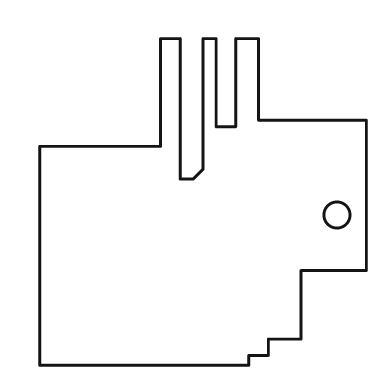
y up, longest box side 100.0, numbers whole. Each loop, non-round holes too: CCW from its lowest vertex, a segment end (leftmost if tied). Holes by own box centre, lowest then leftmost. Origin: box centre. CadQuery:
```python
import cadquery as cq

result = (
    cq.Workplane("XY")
    .moveTo(-50.0, -50.0)
    .lineTo(14.0, -50.0)
    .lineTo(14.0, -47.0)
    .lineTo(20.0, -47.0)
    .lineTo(20.0, -42.0)
    .lineTo(30.0, -42.0)
    .lineTo(30.0, -21.0)
    .lineTo(50.0, -21.0)
    .lineTo(50.0, 25.0)
    .lineTo(17.0, 25.0)
    .lineTo(17.0, 50.0)
    .lineTo(10.0, 50.0)
    .lineTo(10.0, 23.0)
    .lineTo(4.0, 23.0)
    .lineTo(4.0, 50.0)
    .lineTo(0.0, 50.0)
    .lineTo(0.0, 10.0)
    .lineTo(-3.0, 7.0)
    .lineTo(-7.0, 7.0)
    .lineTo(-7.0, 50.0)
    .lineTo(-13.0, 50.0)
    .lineTo(-13.0, 17.0)
    .lineTo(-50.0, 17.0)
    .close()
    .moveTo(41.0, -4.0)
    .circle(4.0)
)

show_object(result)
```